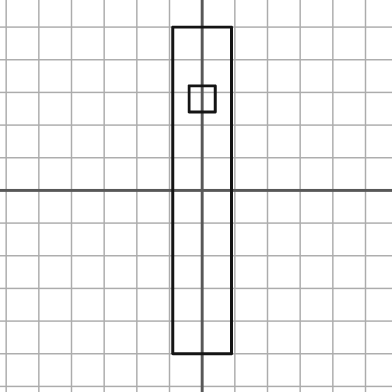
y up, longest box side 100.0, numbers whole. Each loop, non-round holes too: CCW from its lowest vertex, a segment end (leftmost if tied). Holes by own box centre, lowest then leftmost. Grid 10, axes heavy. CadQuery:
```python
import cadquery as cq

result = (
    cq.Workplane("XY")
    .moveTo(-9.0, -50.0)
    .lineTo(9.0, -50.0)
    .lineTo(9.0, 50.0)
    .lineTo(-9.0, 50.0)
    .close()
    .moveTo(-4.0, 24.0)
    .lineTo(4.0, 24.0)
    .lineTo(4.0, 32.0)
    .lineTo(-4.0, 32.0)
    .close()
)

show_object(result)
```